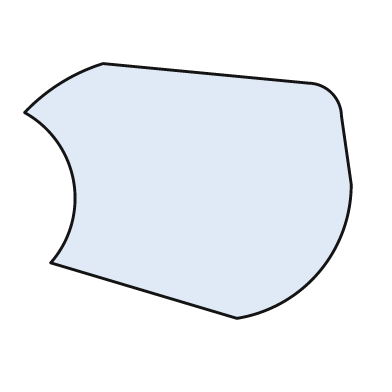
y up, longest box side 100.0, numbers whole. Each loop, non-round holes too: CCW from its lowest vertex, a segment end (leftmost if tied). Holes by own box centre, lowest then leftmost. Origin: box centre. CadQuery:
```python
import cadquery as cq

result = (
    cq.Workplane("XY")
    .moveTo(15.0, -39.0)
    .threePointArc((40.0, -25.0), (50.0, 2.0))
    .lineTo(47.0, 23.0)
    .threePointArc((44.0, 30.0), (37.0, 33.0))
    .lineTo(-26.0, 39.0)
    .threePointArc((-39.0, 33.0), (-50.0, 24.0))
    .threePointArc((-35.0, 3.0), (-42.0, -22.0))
    .close()
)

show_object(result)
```